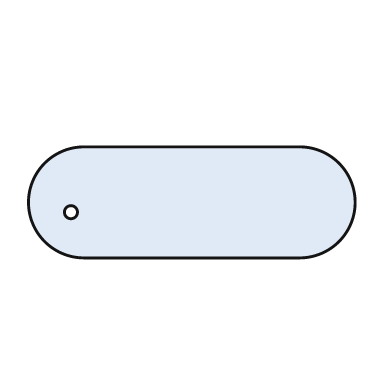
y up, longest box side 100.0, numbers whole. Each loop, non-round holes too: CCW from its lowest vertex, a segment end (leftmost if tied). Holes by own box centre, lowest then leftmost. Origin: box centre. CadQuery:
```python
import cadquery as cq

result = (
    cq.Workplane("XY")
    .moveTo(-33.0, -17.0)
    .lineTo(33.0, -17.0)
    .threePointArc((50.0, 0.0), (33.0, 17.0))
    .lineTo(-33.0, 17.0)
    .threePointArc((-50.0, 0.0), (-33.0, -17.0))
    .close()
    .moveTo(-37.0, -3.0)
    .circle(2.0)
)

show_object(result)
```